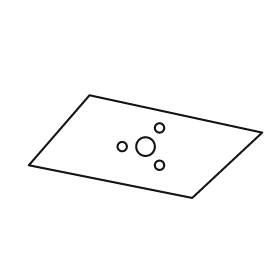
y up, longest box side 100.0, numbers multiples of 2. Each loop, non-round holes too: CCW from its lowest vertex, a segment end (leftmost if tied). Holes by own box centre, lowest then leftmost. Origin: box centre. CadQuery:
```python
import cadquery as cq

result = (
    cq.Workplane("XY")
    .moveTo(20.0, -22.0)
    .lineTo(50.0, 6.0)
    .lineTo(-24.0, 22.0)
    .lineTo(-50.0, -8.0)
    .close()
    .moveTo(6.0, -8.0)
    .circle(2.0)
    .moveTo(-10.0, 0.0)
    .circle(2.0)
    .moveTo(0.0, 0.0)
    .circle(4.0)
    .moveTo(6.0, 8.0)
    .circle(2.0)
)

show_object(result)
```